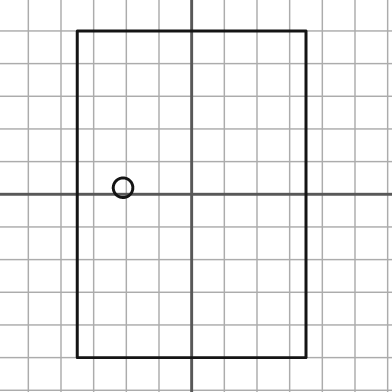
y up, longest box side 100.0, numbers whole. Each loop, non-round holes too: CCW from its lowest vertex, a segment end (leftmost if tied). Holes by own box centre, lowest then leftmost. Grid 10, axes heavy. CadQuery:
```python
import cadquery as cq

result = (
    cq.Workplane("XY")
    .moveTo(-35.0, -50.0)
    .lineTo(35.0, -50.0)
    .lineTo(35.0, 50.0)
    .lineTo(-35.0, 50.0)
    .close()
    .moveTo(-21.0, 2.0)
    .circle(3.0)
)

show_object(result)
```